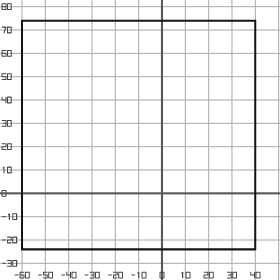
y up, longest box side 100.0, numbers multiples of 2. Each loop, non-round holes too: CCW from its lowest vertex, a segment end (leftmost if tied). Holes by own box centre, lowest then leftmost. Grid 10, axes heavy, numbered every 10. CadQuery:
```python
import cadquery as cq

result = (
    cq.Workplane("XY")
    .moveTo(-60.0, -24.0)
    .lineTo(40.0, -24.0)
    .lineTo(40.0, 74.0)
    .lineTo(-60.0, 74.0)
    .close()
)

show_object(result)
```